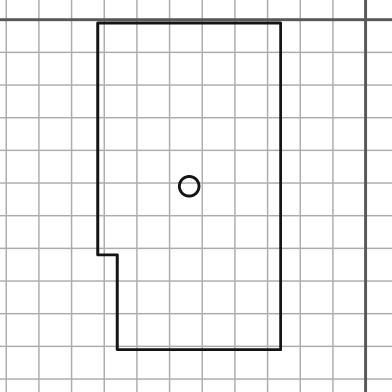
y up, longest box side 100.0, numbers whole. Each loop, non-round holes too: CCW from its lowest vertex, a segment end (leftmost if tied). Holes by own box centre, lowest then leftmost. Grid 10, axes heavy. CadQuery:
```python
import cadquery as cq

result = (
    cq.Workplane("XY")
    .moveTo(-76.0, -101.0)
    .lineTo(-26.0, -101.0)
    .lineTo(-26.0, -1.0)
    .lineTo(-82.0, -1.0)
    .lineTo(-82.0, -72.0)
    .lineTo(-76.0, -72.0)
    .close()
    .moveTo(-54.0, -51.0)
    .circle(3.0)
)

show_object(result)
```